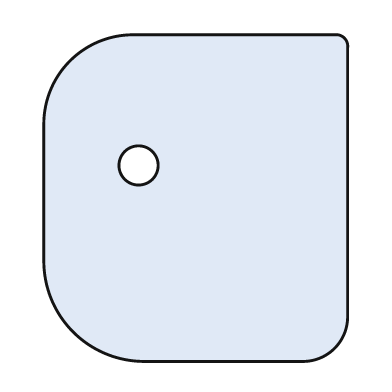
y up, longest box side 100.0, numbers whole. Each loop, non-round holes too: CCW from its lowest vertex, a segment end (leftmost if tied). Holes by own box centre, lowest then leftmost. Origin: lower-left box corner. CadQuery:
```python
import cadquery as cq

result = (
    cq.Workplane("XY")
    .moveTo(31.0, 0.0)
    .lineTo(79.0, 0.0)
    .threePointArc((89.0, 4.0), (93.0, 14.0))
    .lineTo(93.0, 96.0)
    .threePointArc((92.0, 99.0), (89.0, 100.0))
    .lineTo(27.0, 100.0)
    .threePointArc((8.0, 92.0), (0.0, 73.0))
    .lineTo(0.0, 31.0)
    .threePointArc((9.0, 9.0), (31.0, 0.0))
    .close()
    .moveTo(29.0, 60.0)
    .circle(6.0)
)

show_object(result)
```